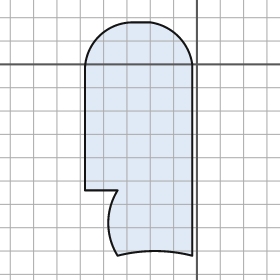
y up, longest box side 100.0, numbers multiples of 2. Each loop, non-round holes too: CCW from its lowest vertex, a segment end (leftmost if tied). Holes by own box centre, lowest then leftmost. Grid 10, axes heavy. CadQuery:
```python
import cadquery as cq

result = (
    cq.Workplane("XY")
    .moveTo(-34.0, -82.0)
    .threePointArc((-18.0, -80.0), (-2.0, -82.0))
    .lineTo(-2.0, 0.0)
    .threePointArc((-8.0, 12.0), (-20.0, 18.0))
    .lineTo(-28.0, 18.0)
    .threePointArc((-42.0, 12.0), (-48.0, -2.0))
    .lineTo(-48.0, -54.0)
    .lineTo(-34.0, -54.0)
    .threePointArc((-38.0, -68.0), (-34.0, -82.0))
    .close()
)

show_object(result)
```